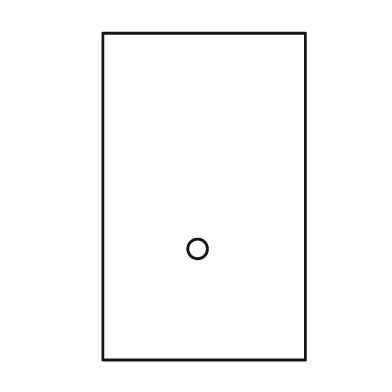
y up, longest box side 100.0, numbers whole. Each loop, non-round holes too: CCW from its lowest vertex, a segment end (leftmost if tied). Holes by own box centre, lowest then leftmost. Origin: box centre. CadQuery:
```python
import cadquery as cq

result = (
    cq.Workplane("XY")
    .moveTo(-31.0, -50.0)
    .lineTo(31.0, -50.0)
    .lineTo(31.0, 50.0)
    .lineTo(-31.0, 50.0)
    .close()
    .moveTo(-2.0, -16.0)
    .circle(3.0)
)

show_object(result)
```